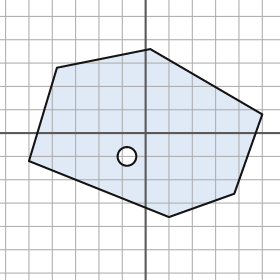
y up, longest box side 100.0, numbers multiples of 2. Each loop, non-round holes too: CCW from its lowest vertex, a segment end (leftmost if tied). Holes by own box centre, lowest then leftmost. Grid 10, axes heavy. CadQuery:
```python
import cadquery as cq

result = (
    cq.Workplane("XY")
    .moveTo(10.0, -36.0)
    .lineTo(38.0, -26.0)
    .lineTo(50.0, 8.0)
    .lineTo(2.0, 36.0)
    .lineTo(-38.0, 28.0)
    .lineTo(-50.0, -12.0)
    .close()
    .moveTo(-8.0, -10.0)
    .circle(4.0)
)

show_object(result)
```